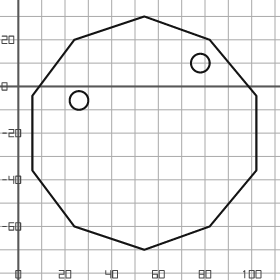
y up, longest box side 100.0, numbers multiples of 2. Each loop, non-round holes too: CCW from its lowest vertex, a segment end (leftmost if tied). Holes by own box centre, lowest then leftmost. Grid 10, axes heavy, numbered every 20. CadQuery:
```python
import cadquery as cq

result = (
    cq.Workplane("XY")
    .moveTo(54.0, -70.0)
    .lineTo(82.0, -60.0)
    .lineTo(102.0, -36.0)
    .lineTo(102.0, -4.0)
    .lineTo(82.0, 20.0)
    .lineTo(54.0, 30.0)
    .lineTo(24.0, 20.0)
    .lineTo(6.0, -4.0)
    .lineTo(6.0, -36.0)
    .lineTo(24.0, -60.0)
    .close()
    .moveTo(26.0, -6.0)
    .circle(4.0)
    .moveTo(78.0, 10.0)
    .circle(4.0)
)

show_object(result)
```